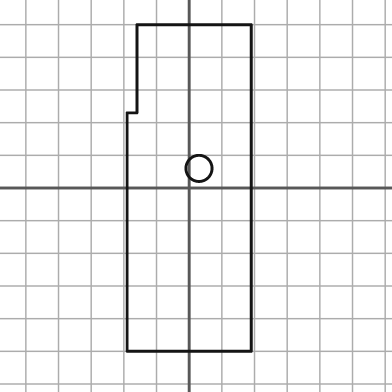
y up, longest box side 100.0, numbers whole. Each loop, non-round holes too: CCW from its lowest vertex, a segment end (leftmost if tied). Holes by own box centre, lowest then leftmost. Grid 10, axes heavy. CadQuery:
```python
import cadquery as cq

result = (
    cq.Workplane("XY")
    .moveTo(-19.0, -50.0)
    .lineTo(19.0, -50.0)
    .lineTo(19.0, 50.0)
    .lineTo(-16.0, 50.0)
    .lineTo(-16.0, 23.0)
    .lineTo(-19.0, 23.0)
    .close()
    .moveTo(3.0, 6.0)
    .circle(4.0)
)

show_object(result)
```